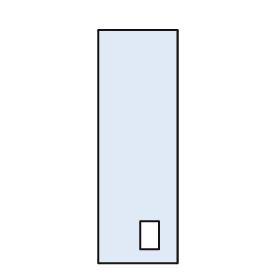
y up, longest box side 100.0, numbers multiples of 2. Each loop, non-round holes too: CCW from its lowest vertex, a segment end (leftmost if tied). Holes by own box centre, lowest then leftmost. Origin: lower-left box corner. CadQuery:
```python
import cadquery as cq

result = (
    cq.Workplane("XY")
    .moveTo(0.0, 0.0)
    .lineTo(34.0, 0.0)
    .lineTo(34.0, 100.0)
    .lineTo(0.0, 100.0)
    .close()
    .moveTo(18.0, 6.0)
    .lineTo(26.0, 6.0)
    .lineTo(26.0, 18.0)
    .lineTo(18.0, 18.0)
    .close()
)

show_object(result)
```